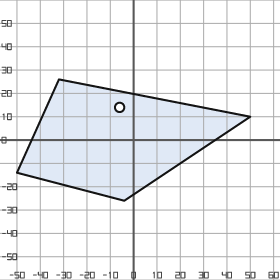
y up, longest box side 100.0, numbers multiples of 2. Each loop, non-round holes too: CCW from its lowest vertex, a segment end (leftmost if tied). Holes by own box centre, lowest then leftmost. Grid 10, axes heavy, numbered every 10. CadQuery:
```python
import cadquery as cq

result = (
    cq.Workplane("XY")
    .moveTo(-4.0, -26.0)
    .lineTo(50.0, 10.0)
    .lineTo(-32.0, 26.0)
    .lineTo(-50.0, -14.0)
    .close()
    .moveTo(-6.0, 14.0)
    .circle(2.0)
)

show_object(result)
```